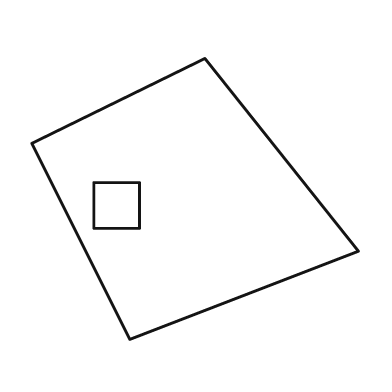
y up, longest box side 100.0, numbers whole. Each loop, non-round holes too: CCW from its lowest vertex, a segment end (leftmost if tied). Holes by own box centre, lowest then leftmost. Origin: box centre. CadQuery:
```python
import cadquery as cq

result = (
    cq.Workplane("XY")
    .moveTo(-20.0, -43.0)
    .lineTo(50.0, -16.0)
    .lineTo(3.0, 43.0)
    .lineTo(-50.0, 17.0)
    .close()
    .moveTo(-31.0, -9.0)
    .lineTo(-17.0, -9.0)
    .lineTo(-17.0, 5.0)
    .lineTo(-31.0, 5.0)
    .close()
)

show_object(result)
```